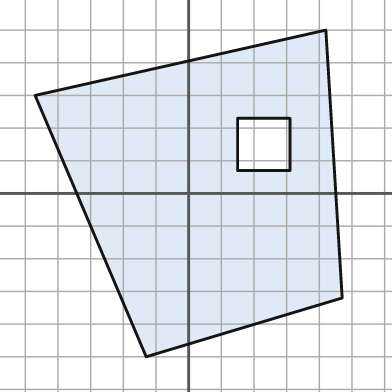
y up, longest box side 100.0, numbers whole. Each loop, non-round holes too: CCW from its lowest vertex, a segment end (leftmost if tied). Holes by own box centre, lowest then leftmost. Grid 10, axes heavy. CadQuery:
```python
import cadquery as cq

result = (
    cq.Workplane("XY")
    .moveTo(-13.0, -50.0)
    .lineTo(47.0, -32.0)
    .lineTo(42.0, 50.0)
    .lineTo(-47.0, 30.0)
    .close()
    .moveTo(15.0, 7.0)
    .lineTo(31.0, 7.0)
    .lineTo(31.0, 23.0)
    .lineTo(15.0, 23.0)
    .close()
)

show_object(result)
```